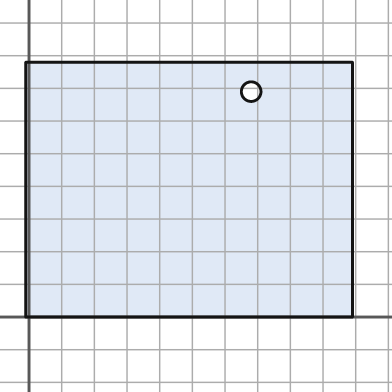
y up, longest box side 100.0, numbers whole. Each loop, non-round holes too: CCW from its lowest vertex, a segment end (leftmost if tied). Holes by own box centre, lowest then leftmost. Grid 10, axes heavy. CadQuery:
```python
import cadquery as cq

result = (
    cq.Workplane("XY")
    .moveTo(-1.0, 0.0)
    .lineTo(99.0, 0.0)
    .lineTo(99.0, 78.0)
    .lineTo(-1.0, 78.0)
    .close()
    .moveTo(68.0, 69.0)
    .circle(3.0)
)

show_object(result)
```